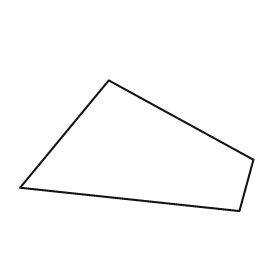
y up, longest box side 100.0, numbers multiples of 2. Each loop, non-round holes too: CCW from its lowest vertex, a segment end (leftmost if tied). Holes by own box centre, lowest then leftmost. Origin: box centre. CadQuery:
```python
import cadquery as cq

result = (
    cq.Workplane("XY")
    .moveTo(44.0, -28.0)
    .lineTo(50.0, -6.0)
    .lineTo(-12.0, 28.0)
    .lineTo(-50.0, -18.0)
    .close()
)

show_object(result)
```